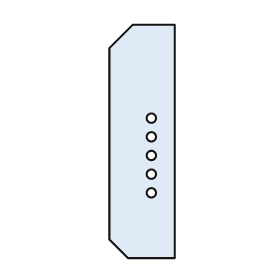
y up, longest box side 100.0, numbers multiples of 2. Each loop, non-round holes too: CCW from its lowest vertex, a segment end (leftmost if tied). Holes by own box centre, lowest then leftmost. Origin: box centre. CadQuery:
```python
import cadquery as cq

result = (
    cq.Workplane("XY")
    .moveTo(-6.0, -50.0)
    .lineTo(14.0, -50.0)
    .lineTo(14.0, 50.0)
    .lineTo(-4.0, 50.0)
    .lineTo(-14.0, 40.0)
    .lineTo(-14.0, -42.0)
    .close()
    .moveTo(4.0, -22.0)
    .circle(2.0)
    .moveTo(4.0, -14.0)
    .circle(2.0)
    .moveTo(4.0, -6.0)
    .circle(2.0)
    .moveTo(4.0, 2.0)
    .circle(2.0)
    .moveTo(4.0, 10.0)
    .circle(2.0)
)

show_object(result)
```